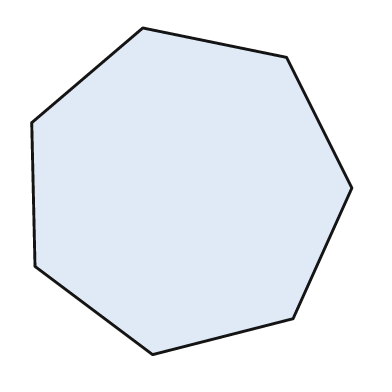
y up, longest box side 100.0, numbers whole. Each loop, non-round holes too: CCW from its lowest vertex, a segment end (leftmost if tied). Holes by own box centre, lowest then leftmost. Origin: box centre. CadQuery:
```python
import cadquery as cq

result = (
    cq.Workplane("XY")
    .moveTo(-12.0, -50.0)
    .lineTo(31.0, -39.0)
    .lineTo(49.0, 1.0)
    .lineTo(29.0, 41.0)
    .lineTo(-15.0, 50.0)
    .lineTo(-49.0, 21.0)
    .lineTo(-48.0, -23.0)
    .close()
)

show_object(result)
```